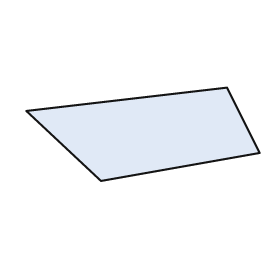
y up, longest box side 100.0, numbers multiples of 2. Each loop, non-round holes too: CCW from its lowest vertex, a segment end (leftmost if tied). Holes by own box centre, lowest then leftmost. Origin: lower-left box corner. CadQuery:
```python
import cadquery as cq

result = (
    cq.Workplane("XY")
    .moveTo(32.0, 0.0)
    .lineTo(100.0, 12.0)
    .lineTo(86.0, 40.0)
    .lineTo(0.0, 30.0)
    .close()
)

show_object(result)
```